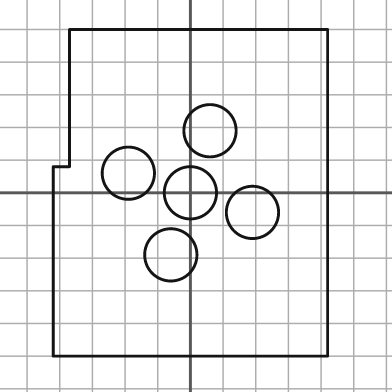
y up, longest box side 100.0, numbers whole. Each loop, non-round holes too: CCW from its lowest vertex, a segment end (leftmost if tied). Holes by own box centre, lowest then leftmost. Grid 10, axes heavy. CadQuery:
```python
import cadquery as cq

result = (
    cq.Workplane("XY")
    .moveTo(-42.0, -50.0)
    .lineTo(42.0, -50.0)
    .lineTo(42.0, 50.0)
    .lineTo(-37.0, 50.0)
    .lineTo(-37.0, 8.0)
    .lineTo(-42.0, 8.0)
    .close()
    .moveTo(-6.0, -19.0)
    .circle(8.0)
    .moveTo(19.0, -6.0)
    .circle(8.0)
    .moveTo(0.0, 0.0)
    .circle(8.0)
    .moveTo(-19.0, 6.0)
    .circle(8.0)
    .moveTo(6.0, 19.0)
    .circle(8.0)
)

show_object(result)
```